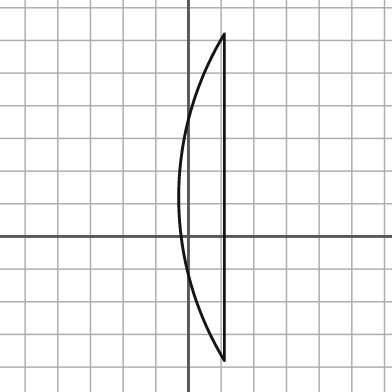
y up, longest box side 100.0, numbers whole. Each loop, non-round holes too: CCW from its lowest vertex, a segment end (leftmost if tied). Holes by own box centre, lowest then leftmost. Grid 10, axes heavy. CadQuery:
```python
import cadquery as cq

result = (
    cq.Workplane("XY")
    .moveTo(11.0, -38.0)
    .lineTo(11.0, 62.0)
    .threePointArc((-3.0, 12.0), (11.0, -38.0))
    .close()
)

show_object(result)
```